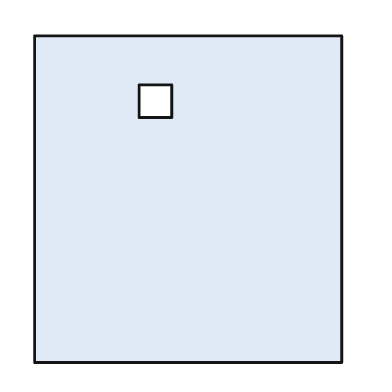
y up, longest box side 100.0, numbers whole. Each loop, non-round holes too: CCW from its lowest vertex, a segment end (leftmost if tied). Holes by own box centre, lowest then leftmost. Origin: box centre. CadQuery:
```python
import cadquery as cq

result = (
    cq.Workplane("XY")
    .moveTo(-47.0, -50.0)
    .lineTo(47.0, -50.0)
    .lineTo(47.0, 50.0)
    .lineTo(-47.0, 50.0)
    .close()
    .moveTo(-15.0, 25.0)
    .lineTo(-5.0, 25.0)
    .lineTo(-5.0, 35.0)
    .lineTo(-15.0, 35.0)
    .close()
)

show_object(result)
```